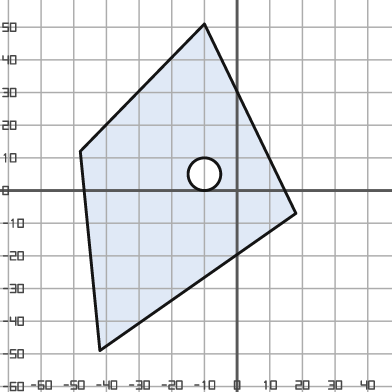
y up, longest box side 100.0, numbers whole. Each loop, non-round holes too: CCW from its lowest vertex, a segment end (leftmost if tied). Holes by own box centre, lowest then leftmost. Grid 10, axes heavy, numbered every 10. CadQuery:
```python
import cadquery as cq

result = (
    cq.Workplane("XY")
    .moveTo(-42.0, -49.0)
    .lineTo(18.0, -7.0)
    .lineTo(-10.0, 51.0)
    .lineTo(-48.0, 12.0)
    .close()
    .moveTo(-10.0, 5.0)
    .circle(5.0)
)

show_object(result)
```